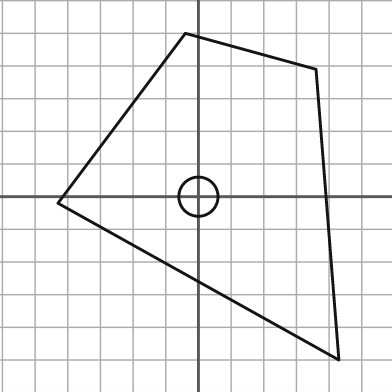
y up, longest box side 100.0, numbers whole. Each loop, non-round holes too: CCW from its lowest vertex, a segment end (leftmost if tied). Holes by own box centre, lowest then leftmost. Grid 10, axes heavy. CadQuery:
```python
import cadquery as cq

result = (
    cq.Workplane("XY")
    .moveTo(43.0, -50.0)
    .lineTo(36.0, 39.0)
    .lineTo(-4.0, 50.0)
    .lineTo(-43.0, -2.0)
    .close()
    .moveTo(0.0, 0.0)
    .circle(6.0)
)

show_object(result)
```